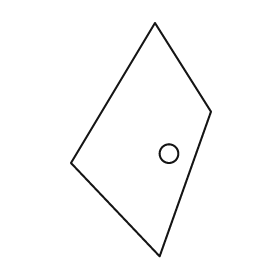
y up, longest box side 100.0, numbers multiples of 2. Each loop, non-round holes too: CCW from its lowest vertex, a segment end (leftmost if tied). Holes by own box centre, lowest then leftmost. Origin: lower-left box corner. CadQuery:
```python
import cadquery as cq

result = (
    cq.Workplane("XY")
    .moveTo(38.0, 0.0)
    .lineTo(60.0, 62.0)
    .lineTo(36.0, 100.0)
    .lineTo(0.0, 40.0)
    .close()
    .moveTo(42.0, 44.0)
    .circle(4.0)
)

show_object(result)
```